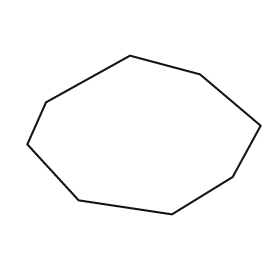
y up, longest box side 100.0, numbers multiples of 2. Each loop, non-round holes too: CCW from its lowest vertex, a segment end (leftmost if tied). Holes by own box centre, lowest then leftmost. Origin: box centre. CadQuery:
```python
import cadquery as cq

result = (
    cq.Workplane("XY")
    .moveTo(12.0, -34.0)
    .lineTo(38.0, -18.0)
    .lineTo(50.0, 4.0)
    .lineTo(24.0, 26.0)
    .lineTo(-6.0, 34.0)
    .lineTo(-42.0, 14.0)
    .lineTo(-50.0, -4.0)
    .lineTo(-28.0, -28.0)
    .close()
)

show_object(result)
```